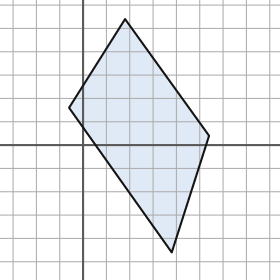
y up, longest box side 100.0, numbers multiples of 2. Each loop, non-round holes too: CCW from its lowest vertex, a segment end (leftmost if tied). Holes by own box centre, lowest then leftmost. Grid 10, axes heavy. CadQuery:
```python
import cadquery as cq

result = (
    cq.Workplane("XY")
    .moveTo(38.0, -46.0)
    .lineTo(54.0, 4.0)
    .lineTo(18.0, 54.0)
    .lineTo(-6.0, 16.0)
    .close()
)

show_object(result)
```